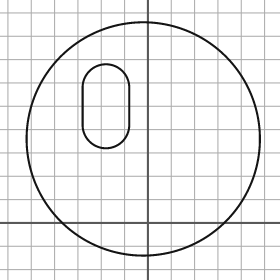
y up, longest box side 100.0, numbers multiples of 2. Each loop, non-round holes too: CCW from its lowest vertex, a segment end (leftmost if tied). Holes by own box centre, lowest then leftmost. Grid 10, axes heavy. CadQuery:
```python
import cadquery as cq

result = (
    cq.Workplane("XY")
    .moveTo(-2.0, 36.0)
    .circle(50.0)
    .moveTo(-28.0, 42.0)
    .threePointArc((-18.0, 32.0), (-8.0, 42.0))
    .lineTo(-8.0, 58.0)
    .threePointArc((-18.0, 68.0), (-28.0, 58.0))
    .close()
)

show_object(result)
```